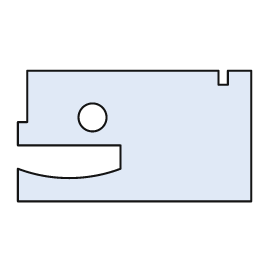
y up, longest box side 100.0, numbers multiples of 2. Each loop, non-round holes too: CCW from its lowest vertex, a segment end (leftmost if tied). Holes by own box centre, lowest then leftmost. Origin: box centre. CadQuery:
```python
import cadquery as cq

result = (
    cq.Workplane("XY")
    .moveTo(-50.0, -28.0)
    .lineTo(50.0, -28.0)
    .lineTo(50.0, 28.0)
    .lineTo(40.0, 28.0)
    .lineTo(40.0, 22.0)
    .lineTo(36.0, 22.0)
    .lineTo(36.0, 28.0)
    .lineTo(-46.0, 28.0)
    .lineTo(-46.0, 6.0)
    .lineTo(-50.0, 6.0)
    .lineTo(-50.0, -4.0)
    .lineTo(-6.0, -4.0)
    .lineTo(-6.0, -14.0)
    .threePointArc((-28.0, -18.0), (-50.0, -14.0))
    .close()
    .moveTo(-18.0, 8.0)
    .circle(6.0)
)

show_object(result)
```